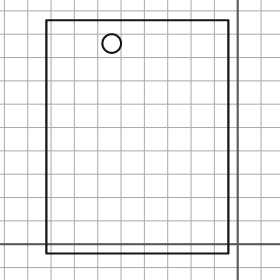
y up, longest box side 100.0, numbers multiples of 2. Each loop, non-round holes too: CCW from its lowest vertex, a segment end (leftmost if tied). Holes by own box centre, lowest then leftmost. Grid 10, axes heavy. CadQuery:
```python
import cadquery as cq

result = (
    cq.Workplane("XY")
    .moveTo(-82.0, -4.0)
    .lineTo(-4.0, -4.0)
    .lineTo(-4.0, 96.0)
    .lineTo(-82.0, 96.0)
    .close()
    .moveTo(-54.0, 86.0)
    .circle(4.0)
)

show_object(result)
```